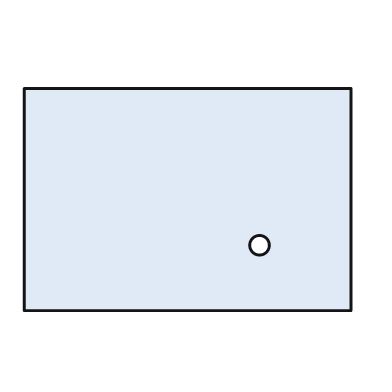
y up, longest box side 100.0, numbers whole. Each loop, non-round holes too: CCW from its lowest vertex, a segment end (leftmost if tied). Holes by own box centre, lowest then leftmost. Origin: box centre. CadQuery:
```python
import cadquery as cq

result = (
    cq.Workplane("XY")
    .moveTo(-50.0, -34.0)
    .lineTo(50.0, -34.0)
    .lineTo(50.0, 34.0)
    .lineTo(-50.0, 34.0)
    .close()
    .moveTo(22.0, -14.0)
    .circle(3.0)
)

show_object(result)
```